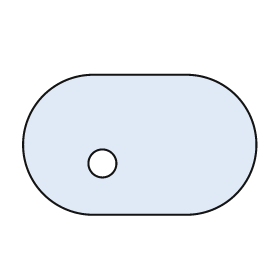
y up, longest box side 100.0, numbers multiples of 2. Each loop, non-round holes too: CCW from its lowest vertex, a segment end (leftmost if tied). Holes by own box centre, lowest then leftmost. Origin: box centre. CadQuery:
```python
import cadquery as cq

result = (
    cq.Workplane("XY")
    .moveTo(-20.0, -30.0)
    .lineTo(20.0, -30.0)
    .threePointArc((50.0, 0.0), (20.0, 30.0))
    .lineTo(-20.0, 30.0)
    .threePointArc((-50.0, 0.0), (-20.0, -30.0))
    .close()
    .moveTo(-16.0, -8.0)
    .circle(6.0)
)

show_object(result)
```